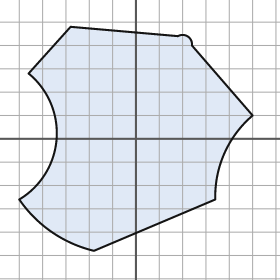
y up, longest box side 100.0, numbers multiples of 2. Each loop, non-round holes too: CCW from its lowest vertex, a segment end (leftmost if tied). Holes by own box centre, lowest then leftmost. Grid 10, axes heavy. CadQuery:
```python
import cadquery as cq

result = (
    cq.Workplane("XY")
    .moveTo(-18.0, -48.0)
    .lineTo(34.0, -26.0)
    .threePointArc((38.0, -6.0), (50.0, 10.0))
    .lineTo(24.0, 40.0)
    .threePointArc((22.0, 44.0), (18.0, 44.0))
    .lineTo(-28.0, 48.0)
    .lineTo(-46.0, 28.0)
    .threePointArc((-34.0, 0.0), (-50.0, -26.0))
    .threePointArc((-36.0, -40.0), (-18.0, -48.0))
    .close()
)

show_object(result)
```